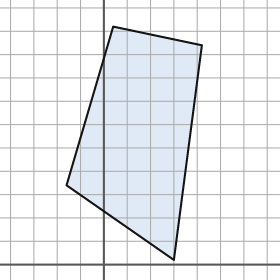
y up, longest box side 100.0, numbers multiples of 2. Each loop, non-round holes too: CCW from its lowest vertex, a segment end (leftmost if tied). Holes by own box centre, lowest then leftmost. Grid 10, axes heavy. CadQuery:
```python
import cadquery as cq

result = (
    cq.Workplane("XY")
    .moveTo(30.0, 2.0)
    .lineTo(42.0, 94.0)
    .lineTo(4.0, 102.0)
    .lineTo(-16.0, 34.0)
    .close()
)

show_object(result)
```